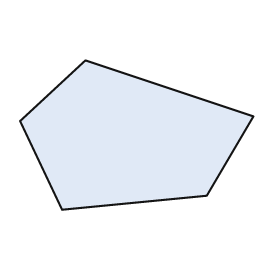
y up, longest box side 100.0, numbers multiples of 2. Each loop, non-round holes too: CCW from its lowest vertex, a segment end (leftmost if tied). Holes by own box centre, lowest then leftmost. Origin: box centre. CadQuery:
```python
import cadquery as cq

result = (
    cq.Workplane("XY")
    .moveTo(-32.0, -32.0)
    .lineTo(30.0, -26.0)
    .lineTo(50.0, 8.0)
    .lineTo(-22.0, 32.0)
    .lineTo(-50.0, 6.0)
    .close()
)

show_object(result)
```